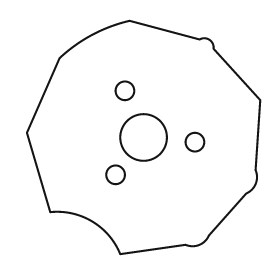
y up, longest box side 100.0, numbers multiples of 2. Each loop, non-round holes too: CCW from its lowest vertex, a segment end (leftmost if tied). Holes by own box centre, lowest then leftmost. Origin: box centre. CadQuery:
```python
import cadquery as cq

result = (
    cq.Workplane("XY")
    .moveTo(-10.0, -50.0)
    .lineTo(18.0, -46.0)
    .threePointArc((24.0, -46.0), (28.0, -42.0))
    .lineTo(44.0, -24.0)
    .threePointArc((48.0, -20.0), (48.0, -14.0))
    .lineTo(50.0, 16.0)
    .lineTo(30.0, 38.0)
    .threePointArc((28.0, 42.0), (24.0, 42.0))
    .lineTo(-6.0, 50.0)
    .threePointArc((-22.0, 44.0), (-36.0, 34.0))
    .lineTo(-50.0, 2.0)
    .lineTo(-40.0, -32.0)
    .threePointArc((-22.0, -36.0), (-10.0, -50.0))
    .close()
    .moveTo(-12.0, -16.0)
    .circle(4.0)
    .moveTo(22.0, -2.0)
    .circle(4.0)
    .moveTo(0.0, 0.0)
    .circle(10.0)
    .moveTo(-8.0, 20.0)
    .circle(4.0)
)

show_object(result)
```